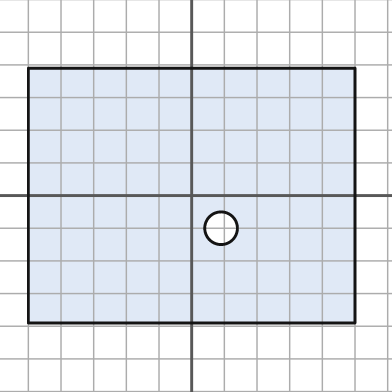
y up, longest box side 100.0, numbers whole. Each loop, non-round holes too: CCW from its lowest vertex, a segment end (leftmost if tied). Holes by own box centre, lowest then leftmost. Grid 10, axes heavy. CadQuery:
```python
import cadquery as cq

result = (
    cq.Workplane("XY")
    .moveTo(-50.0, -39.0)
    .lineTo(50.0, -39.0)
    .lineTo(50.0, 39.0)
    .lineTo(-50.0, 39.0)
    .close()
    .moveTo(9.0, -10.0)
    .circle(5.0)
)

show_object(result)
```